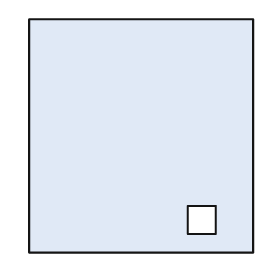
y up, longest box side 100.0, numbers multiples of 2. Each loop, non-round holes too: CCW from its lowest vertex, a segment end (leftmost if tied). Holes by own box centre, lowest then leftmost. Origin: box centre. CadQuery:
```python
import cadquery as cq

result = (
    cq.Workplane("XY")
    .moveTo(-48.0, -50.0)
    .lineTo(48.0, -50.0)
    .lineTo(48.0, 50.0)
    .lineTo(-48.0, 50.0)
    .close()
    .moveTo(20.0, -42.0)
    .lineTo(32.0, -42.0)
    .lineTo(32.0, -30.0)
    .lineTo(20.0, -30.0)
    .close()
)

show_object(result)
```